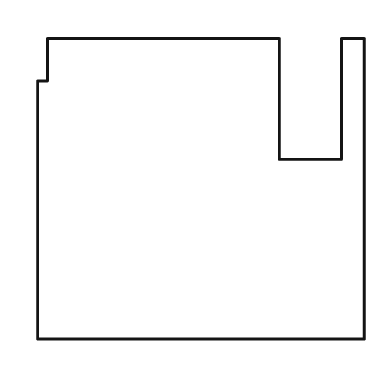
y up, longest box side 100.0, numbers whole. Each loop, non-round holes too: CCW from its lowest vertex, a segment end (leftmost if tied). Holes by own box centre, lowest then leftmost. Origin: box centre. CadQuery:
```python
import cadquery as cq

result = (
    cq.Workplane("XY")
    .moveTo(-50.0, -46.0)
    .lineTo(50.0, -46.0)
    .lineTo(50.0, 46.0)
    .lineTo(43.0, 46.0)
    .lineTo(43.0, 9.0)
    .lineTo(24.0, 9.0)
    .lineTo(24.0, 46.0)
    .lineTo(-47.0, 46.0)
    .lineTo(-47.0, 33.0)
    .lineTo(-50.0, 33.0)
    .close()
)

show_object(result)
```